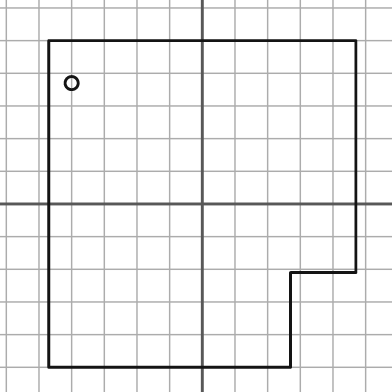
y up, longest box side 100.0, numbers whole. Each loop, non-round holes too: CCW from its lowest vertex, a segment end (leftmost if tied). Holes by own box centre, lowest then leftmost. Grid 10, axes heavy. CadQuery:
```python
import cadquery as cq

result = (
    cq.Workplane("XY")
    .moveTo(-47.0, -50.0)
    .lineTo(27.0, -50.0)
    .lineTo(27.0, -21.0)
    .lineTo(47.0, -21.0)
    .lineTo(47.0, 50.0)
    .lineTo(-47.0, 50.0)
    .close()
    .moveTo(-40.0, 37.0)
    .circle(2.0)
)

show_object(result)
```